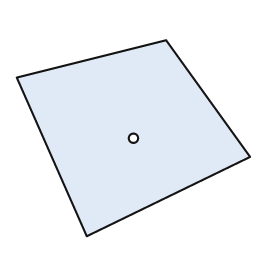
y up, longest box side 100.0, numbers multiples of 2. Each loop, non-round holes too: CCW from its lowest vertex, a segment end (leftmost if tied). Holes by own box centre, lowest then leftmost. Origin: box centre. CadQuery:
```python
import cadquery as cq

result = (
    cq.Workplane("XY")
    .moveTo(-20.0, -42.0)
    .lineTo(50.0, -8.0)
    .lineTo(14.0, 42.0)
    .lineTo(-50.0, 26.0)
    .close()
    .moveTo(0.0, 0.0)
    .circle(2.0)
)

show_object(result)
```